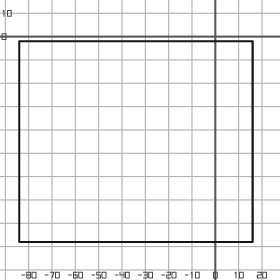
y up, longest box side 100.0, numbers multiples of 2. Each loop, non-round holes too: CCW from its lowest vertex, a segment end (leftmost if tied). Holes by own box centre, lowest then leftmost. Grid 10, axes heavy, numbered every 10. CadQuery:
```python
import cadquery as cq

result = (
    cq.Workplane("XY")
    .moveTo(-84.0, -88.0)
    .lineTo(16.0, -88.0)
    .lineTo(16.0, -2.0)
    .lineTo(-84.0, -2.0)
    .close()
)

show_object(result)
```